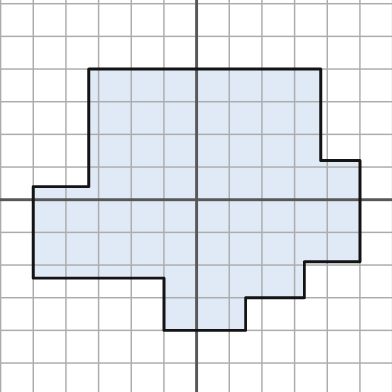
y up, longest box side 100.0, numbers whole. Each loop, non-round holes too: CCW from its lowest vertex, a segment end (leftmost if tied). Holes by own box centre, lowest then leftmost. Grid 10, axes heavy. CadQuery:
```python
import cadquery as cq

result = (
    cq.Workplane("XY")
    .moveTo(-10.0, -40.0)
    .lineTo(15.0, -40.0)
    .lineTo(15.0, -30.0)
    .lineTo(33.0, -30.0)
    .lineTo(33.0, -19.0)
    .lineTo(50.0, -19.0)
    .lineTo(50.0, 12.0)
    .lineTo(38.0, 12.0)
    .lineTo(38.0, 40.0)
    .lineTo(-33.0, 40.0)
    .lineTo(-33.0, 4.0)
    .lineTo(-50.0, 4.0)
    .lineTo(-50.0, -24.0)
    .lineTo(-10.0, -24.0)
    .close()
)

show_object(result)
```